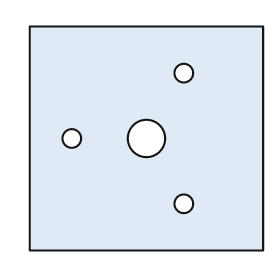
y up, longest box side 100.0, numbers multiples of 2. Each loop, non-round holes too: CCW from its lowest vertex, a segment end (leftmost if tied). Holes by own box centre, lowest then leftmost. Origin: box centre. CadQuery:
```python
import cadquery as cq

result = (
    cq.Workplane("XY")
    .moveTo(-50.0, -48.0)
    .lineTo(50.0, -48.0)
    .lineTo(50.0, 48.0)
    .lineTo(-50.0, 48.0)
    .close()
    .moveTo(16.0, -28.0)
    .circle(4.0)
    .moveTo(-32.0, 0.0)
    .circle(4.0)
    .moveTo(0.0, 0.0)
    .circle(8.0)
    .moveTo(16.0, 28.0)
    .circle(4.0)
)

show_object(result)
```